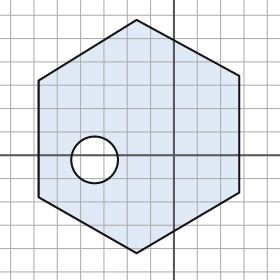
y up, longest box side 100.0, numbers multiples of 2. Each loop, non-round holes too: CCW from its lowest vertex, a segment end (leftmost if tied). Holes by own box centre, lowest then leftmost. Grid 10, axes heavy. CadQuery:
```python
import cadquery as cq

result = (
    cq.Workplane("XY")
    .moveTo(-16.0, -42.0)
    .lineTo(28.0, -16.0)
    .lineTo(28.0, 34.0)
    .lineTo(-16.0, 58.0)
    .lineTo(-58.0, 32.0)
    .lineTo(-58.0, -18.0)
    .close()
    .moveTo(-34.0, -2.0)
    .circle(10.0)
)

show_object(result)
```